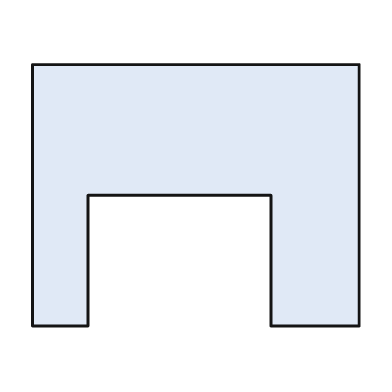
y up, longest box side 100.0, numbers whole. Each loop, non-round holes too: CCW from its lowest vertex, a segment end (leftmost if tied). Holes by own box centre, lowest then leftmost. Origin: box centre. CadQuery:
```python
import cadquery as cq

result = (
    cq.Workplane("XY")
    .moveTo(-50.0, -40.0)
    .lineTo(-33.0, -40.0)
    .lineTo(-33.0, 0.0)
    .lineTo(23.0, 0.0)
    .lineTo(23.0, -40.0)
    .lineTo(50.0, -40.0)
    .lineTo(50.0, 40.0)
    .lineTo(-50.0, 40.0)
    .close()
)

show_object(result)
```